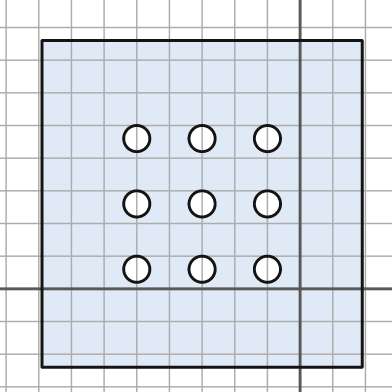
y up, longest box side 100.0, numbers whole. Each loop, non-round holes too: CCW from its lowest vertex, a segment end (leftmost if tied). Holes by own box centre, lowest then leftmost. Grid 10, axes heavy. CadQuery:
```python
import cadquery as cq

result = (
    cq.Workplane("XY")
    .moveTo(-79.0, -24.0)
    .lineTo(19.0, -24.0)
    .lineTo(19.0, 76.0)
    .lineTo(-79.0, 76.0)
    .close()
    .moveTo(-50.0, 6.0)
    .circle(4.0)
    .moveTo(-30.0, 6.0)
    .circle(4.0)
    .moveTo(-10.0, 6.0)
    .circle(4.0)
    .moveTo(-50.0, 26.0)
    .circle(4.0)
    .moveTo(-30.0, 26.0)
    .circle(4.0)
    .moveTo(-10.0, 26.0)
    .circle(4.0)
    .moveTo(-50.0, 46.0)
    .circle(4.0)
    .moveTo(-30.0, 46.0)
    .circle(4.0)
    .moveTo(-10.0, 46.0)
    .circle(4.0)
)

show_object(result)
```